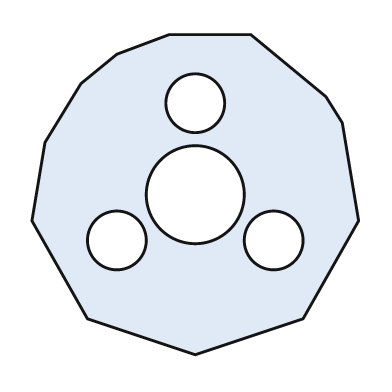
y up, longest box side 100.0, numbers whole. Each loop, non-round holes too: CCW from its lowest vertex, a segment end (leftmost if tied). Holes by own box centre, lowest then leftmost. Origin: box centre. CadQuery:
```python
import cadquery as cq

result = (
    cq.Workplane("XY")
    .moveTo(0.0, -49.0)
    .lineTo(33.0, -38.0)
    .lineTo(50.0, -8.0)
    .lineTo(45.0, 22.0)
    .lineTo(40.0, 30.0)
    .lineTo(17.0, 49.0)
    .lineTo(-8.0, 49.0)
    .lineTo(-24.0, 43.0)
    .lineTo(-35.0, 34.0)
    .lineTo(-46.0, 16.0)
    .lineTo(-50.0, -8.0)
    .lineTo(-33.0, -38.0)
    .close()
    .moveTo(-24.0, -14.0)
    .circle(9.0)
    .moveTo(24.0, -14.0)
    .circle(9.0)
    .moveTo(0.0, 0.0)
    .circle(15.0)
    .moveTo(0.0, 28.0)
    .circle(9.0)
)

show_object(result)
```